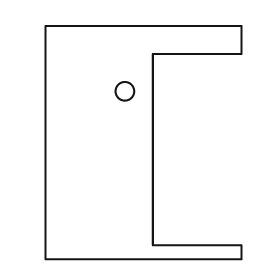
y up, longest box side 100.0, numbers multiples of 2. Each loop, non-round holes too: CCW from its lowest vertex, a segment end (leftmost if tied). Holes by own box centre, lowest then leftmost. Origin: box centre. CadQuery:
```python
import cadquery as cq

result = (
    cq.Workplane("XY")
    .moveTo(-42.0, -50.0)
    .lineTo(42.0, -50.0)
    .lineTo(42.0, -44.0)
    .lineTo(4.0, -44.0)
    .lineTo(4.0, 38.0)
    .lineTo(42.0, 38.0)
    .lineTo(42.0, 50.0)
    .lineTo(-42.0, 50.0)
    .close()
    .moveTo(-8.0, 22.0)
    .circle(4.0)
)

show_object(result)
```